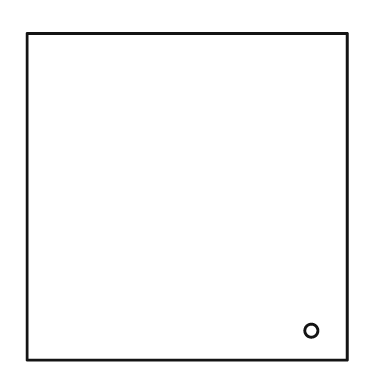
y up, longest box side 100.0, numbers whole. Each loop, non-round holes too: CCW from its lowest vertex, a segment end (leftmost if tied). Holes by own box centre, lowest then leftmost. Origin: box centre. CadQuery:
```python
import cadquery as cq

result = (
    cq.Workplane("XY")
    .moveTo(-49.0, -50.0)
    .lineTo(49.0, -50.0)
    .lineTo(49.0, 50.0)
    .lineTo(-49.0, 50.0)
    .close()
    .moveTo(38.0, -41.0)
    .circle(2.0)
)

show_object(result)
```